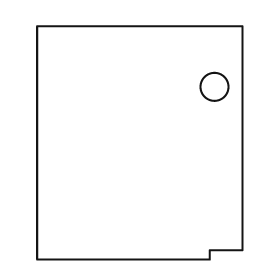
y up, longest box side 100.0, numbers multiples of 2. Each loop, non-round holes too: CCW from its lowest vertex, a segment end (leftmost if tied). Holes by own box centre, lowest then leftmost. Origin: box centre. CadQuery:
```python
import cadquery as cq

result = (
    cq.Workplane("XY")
    .moveTo(-44.0, -50.0)
    .lineTo(30.0, -50.0)
    .lineTo(30.0, -46.0)
    .lineTo(44.0, -46.0)
    .lineTo(44.0, 50.0)
    .lineTo(-44.0, 50.0)
    .close()
    .moveTo(32.0, 24.0)
    .circle(6.0)
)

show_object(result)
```